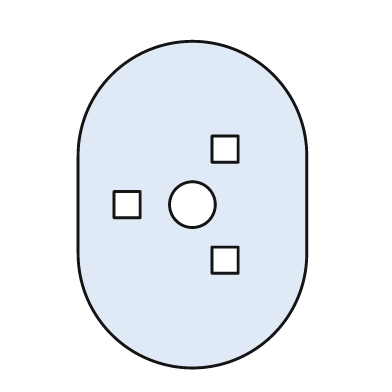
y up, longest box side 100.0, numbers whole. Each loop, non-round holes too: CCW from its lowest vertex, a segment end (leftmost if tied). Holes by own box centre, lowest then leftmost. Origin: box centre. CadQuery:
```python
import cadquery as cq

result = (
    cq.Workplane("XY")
    .moveTo(-35.0, -15.0)
    .threePointArc((0.0, -50.0), (35.0, -15.0))
    .lineTo(35.0, 15.0)
    .threePointArc((0.0, 50.0), (-35.0, 15.0))
    .close()
    .moveTo(6.0, -21.0)
    .lineTo(14.0, -21.0)
    .lineTo(14.0, -13.0)
    .lineTo(6.0, -13.0)
    .close()
    .moveTo(-24.0, -4.0)
    .lineTo(-16.0, -4.0)
    .lineTo(-16.0, 4.0)
    .lineTo(-24.0, 4.0)
    .close()
    .moveTo(0.0, 0.0)
    .circle(7.0)
    .moveTo(6.0, 13.0)
    .lineTo(14.0, 13.0)
    .lineTo(14.0, 21.0)
    .lineTo(6.0, 21.0)
    .close()
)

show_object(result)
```